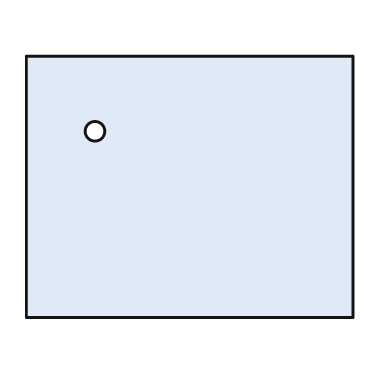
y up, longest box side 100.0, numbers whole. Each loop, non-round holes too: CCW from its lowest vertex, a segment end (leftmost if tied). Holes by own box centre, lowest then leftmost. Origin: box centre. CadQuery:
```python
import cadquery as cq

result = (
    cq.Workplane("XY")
    .moveTo(-50.0, -40.0)
    .lineTo(50.0, -40.0)
    .lineTo(50.0, 40.0)
    .lineTo(-50.0, 40.0)
    .close()
    .moveTo(-29.0, 17.0)
    .circle(3.0)
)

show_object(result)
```